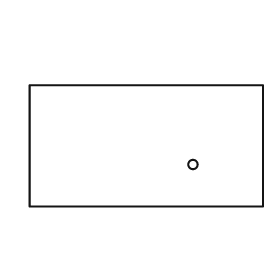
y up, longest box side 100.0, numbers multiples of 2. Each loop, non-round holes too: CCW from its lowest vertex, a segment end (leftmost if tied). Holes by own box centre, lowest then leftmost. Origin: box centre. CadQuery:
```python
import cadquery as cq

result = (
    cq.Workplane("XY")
    .moveTo(-50.0, -26.0)
    .lineTo(50.0, -26.0)
    .lineTo(50.0, 26.0)
    .lineTo(-50.0, 26.0)
    .close()
    .moveTo(20.0, -8.0)
    .circle(2.0)
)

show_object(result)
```